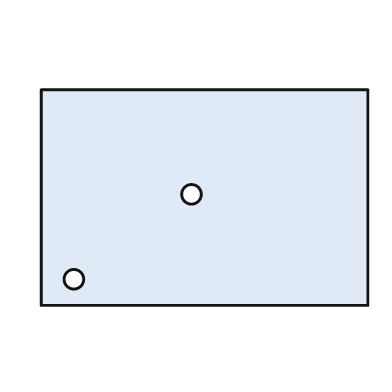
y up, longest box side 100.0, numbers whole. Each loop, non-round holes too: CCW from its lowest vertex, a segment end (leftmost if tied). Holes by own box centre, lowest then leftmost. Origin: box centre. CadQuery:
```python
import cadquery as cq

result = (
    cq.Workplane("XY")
    .moveTo(-50.0, -33.0)
    .lineTo(50.0, -33.0)
    .lineTo(50.0, 33.0)
    .lineTo(-50.0, 33.0)
    .close()
    .moveTo(-40.0, -25.0)
    .circle(3.0)
    .moveTo(-4.0, 1.0)
    .circle(3.0)
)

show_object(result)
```